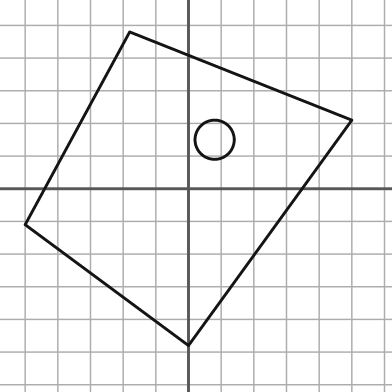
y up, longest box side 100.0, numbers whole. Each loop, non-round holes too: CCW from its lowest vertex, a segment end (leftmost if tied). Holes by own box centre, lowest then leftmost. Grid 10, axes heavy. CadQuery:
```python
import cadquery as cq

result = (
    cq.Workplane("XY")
    .moveTo(0.0, -48.0)
    .lineTo(50.0, 21.0)
    .lineTo(-18.0, 48.0)
    .lineTo(-50.0, -11.0)
    .close()
    .moveTo(8.0, 15.0)
    .circle(6.0)
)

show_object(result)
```